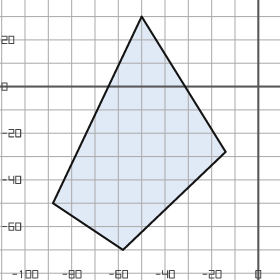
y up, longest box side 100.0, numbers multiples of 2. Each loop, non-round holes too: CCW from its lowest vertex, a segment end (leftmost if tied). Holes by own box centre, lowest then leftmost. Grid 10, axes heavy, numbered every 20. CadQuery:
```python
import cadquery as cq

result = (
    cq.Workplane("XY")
    .moveTo(-58.0, -70.0)
    .lineTo(-14.0, -28.0)
    .lineTo(-50.0, 30.0)
    .lineTo(-88.0, -50.0)
    .close()
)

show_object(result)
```